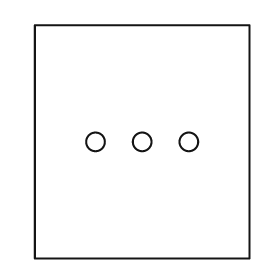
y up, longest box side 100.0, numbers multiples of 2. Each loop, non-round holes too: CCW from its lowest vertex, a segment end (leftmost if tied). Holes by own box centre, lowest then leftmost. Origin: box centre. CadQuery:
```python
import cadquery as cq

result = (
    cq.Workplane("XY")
    .moveTo(-46.0, -50.0)
    .lineTo(46.0, -50.0)
    .lineTo(46.0, 50.0)
    .lineTo(-46.0, 50.0)
    .close()
    .moveTo(-20.0, 0.0)
    .circle(4.0)
    .moveTo(0.0, 0.0)
    .circle(4.0)
    .moveTo(20.0, 0.0)
    .circle(4.0)
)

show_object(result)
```